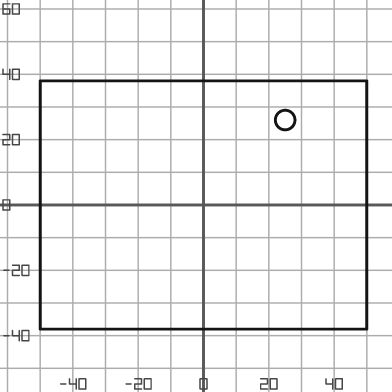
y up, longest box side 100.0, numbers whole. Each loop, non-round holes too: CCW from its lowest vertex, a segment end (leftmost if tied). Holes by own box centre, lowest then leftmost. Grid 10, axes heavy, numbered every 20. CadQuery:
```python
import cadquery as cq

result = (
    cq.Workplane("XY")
    .moveTo(-50.0, -38.0)
    .lineTo(50.0, -38.0)
    .lineTo(50.0, 38.0)
    .lineTo(-50.0, 38.0)
    .close()
    .moveTo(25.0, 26.0)
    .circle(3.0)
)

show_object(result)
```